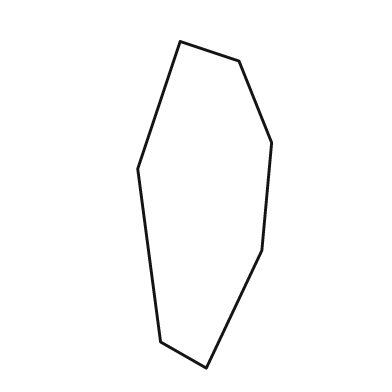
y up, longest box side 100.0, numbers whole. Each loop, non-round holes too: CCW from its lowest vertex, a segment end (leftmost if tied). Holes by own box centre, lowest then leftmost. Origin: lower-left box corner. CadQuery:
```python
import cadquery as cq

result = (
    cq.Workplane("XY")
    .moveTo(21.0, 0.0)
    .lineTo(38.0, 36.0)
    .lineTo(41.0, 69.0)
    .lineTo(31.0, 94.0)
    .lineTo(13.0, 100.0)
    .lineTo(0.0, 61.0)
    .lineTo(7.0, 8.0)
    .close()
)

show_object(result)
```